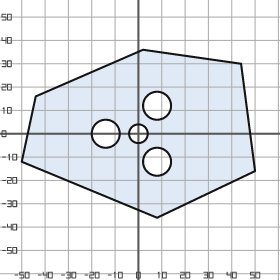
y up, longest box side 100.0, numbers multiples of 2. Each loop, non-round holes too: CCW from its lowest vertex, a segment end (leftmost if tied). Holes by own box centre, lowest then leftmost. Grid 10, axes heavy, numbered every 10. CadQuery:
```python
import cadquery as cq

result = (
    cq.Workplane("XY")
    .moveTo(8.0, -36.0)
    .lineTo(50.0, -16.0)
    .lineTo(44.0, 30.0)
    .lineTo(2.0, 36.0)
    .lineTo(-44.0, 16.0)
    .lineTo(-50.0, -12.0)
    .close()
    .moveTo(8.0, -12.0)
    .circle(6.0)
    .moveTo(-14.0, 0.0)
    .circle(6.0)
    .moveTo(0.0, 0.0)
    .circle(4.0)
    .moveTo(8.0, 12.0)
    .circle(6.0)
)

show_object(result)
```